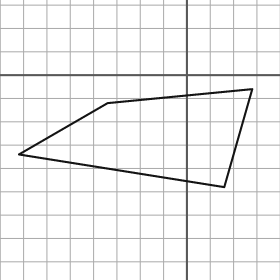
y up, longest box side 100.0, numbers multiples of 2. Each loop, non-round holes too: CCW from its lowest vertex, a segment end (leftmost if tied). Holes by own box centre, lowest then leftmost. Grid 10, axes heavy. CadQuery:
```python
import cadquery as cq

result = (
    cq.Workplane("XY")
    .moveTo(16.0, -48.0)
    .lineTo(28.0, -6.0)
    .lineTo(-34.0, -12.0)
    .lineTo(-72.0, -34.0)
    .close()
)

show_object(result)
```